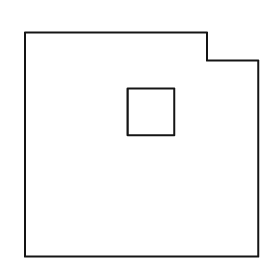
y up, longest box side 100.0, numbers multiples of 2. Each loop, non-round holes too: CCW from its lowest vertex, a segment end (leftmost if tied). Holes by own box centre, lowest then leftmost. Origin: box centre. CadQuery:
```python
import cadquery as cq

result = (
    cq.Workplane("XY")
    .moveTo(-50.0, -48.0)
    .lineTo(50.0, -48.0)
    .lineTo(50.0, 36.0)
    .lineTo(28.0, 36.0)
    .lineTo(28.0, 48.0)
    .lineTo(-50.0, 48.0)
    .close()
    .moveTo(-6.0, 4.0)
    .lineTo(14.0, 4.0)
    .lineTo(14.0, 24.0)
    .lineTo(-6.0, 24.0)
    .close()
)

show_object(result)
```